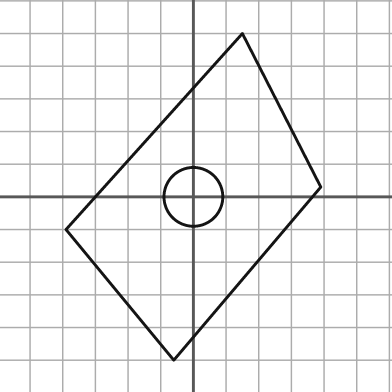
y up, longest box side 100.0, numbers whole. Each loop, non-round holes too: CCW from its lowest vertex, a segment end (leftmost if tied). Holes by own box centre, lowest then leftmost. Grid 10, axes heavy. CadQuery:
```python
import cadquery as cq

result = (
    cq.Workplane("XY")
    .moveTo(-6.0, -50.0)
    .lineTo(39.0, 3.0)
    .lineTo(15.0, 50.0)
    .lineTo(-39.0, -10.0)
    .close()
    .moveTo(0.0, 0.0)
    .circle(9.0)
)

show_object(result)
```